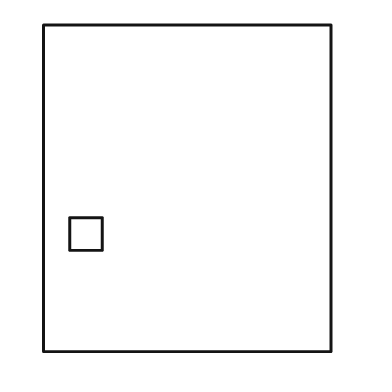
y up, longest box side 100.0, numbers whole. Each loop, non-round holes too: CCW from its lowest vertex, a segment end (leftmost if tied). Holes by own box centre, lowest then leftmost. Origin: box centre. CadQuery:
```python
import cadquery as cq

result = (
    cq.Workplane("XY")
    .moveTo(-44.0, -50.0)
    .lineTo(44.0, -50.0)
    .lineTo(44.0, 50.0)
    .lineTo(-44.0, 50.0)
    .close()
    .moveTo(-36.0, -19.0)
    .lineTo(-26.0, -19.0)
    .lineTo(-26.0, -9.0)
    .lineTo(-36.0, -9.0)
    .close()
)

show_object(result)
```